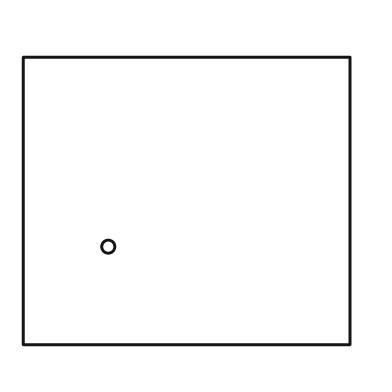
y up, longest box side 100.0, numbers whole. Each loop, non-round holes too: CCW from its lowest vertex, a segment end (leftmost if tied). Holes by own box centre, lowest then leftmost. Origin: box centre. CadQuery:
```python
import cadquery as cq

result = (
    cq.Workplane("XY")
    .moveTo(-50.0, -44.0)
    .lineTo(50.0, -44.0)
    .lineTo(50.0, 44.0)
    .lineTo(-50.0, 44.0)
    .close()
    .moveTo(-24.0, -14.0)
    .circle(2.0)
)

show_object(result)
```